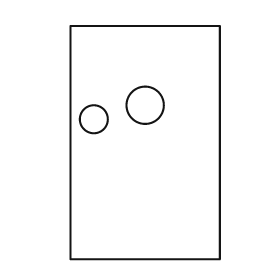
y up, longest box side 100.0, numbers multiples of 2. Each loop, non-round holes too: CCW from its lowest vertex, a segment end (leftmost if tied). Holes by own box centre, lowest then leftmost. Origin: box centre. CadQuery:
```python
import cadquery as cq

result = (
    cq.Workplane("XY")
    .moveTo(-32.0, -50.0)
    .lineTo(32.0, -50.0)
    .lineTo(32.0, 50.0)
    .lineTo(-32.0, 50.0)
    .close()
    .moveTo(-22.0, 10.0)
    .circle(6.0)
    .moveTo(0.0, 16.0)
    .circle(8.0)
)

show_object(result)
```